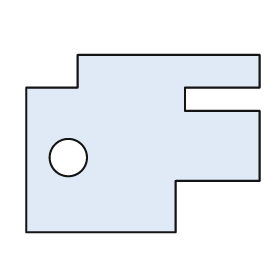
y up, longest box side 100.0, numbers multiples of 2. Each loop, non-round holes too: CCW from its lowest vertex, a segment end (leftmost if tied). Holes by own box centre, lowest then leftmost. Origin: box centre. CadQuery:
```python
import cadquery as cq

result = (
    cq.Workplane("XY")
    .moveTo(-50.0, -38.0)
    .lineTo(14.0, -38.0)
    .lineTo(14.0, -16.0)
    .lineTo(50.0, -16.0)
    .lineTo(50.0, 14.0)
    .lineTo(18.0, 14.0)
    .lineTo(18.0, 24.0)
    .lineTo(50.0, 24.0)
    .lineTo(50.0, 38.0)
    .lineTo(-28.0, 38.0)
    .lineTo(-28.0, 24.0)
    .lineTo(-50.0, 24.0)
    .close()
    .moveTo(-32.0, -6.0)
    .circle(8.0)
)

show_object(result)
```